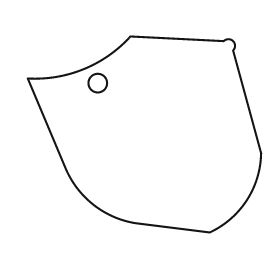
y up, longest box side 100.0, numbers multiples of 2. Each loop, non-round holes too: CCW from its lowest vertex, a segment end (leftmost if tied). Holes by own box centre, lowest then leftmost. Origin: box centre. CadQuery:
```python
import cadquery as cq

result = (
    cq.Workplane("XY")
    .moveTo(28.0, -42.0)
    .threePointArc((44.0, -28.0), (50.0, -8.0))
    .lineTo(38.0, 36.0)
    .threePointArc((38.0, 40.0), (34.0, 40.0))
    .lineTo(-6.0, 42.0)
    .threePointArc((-26.0, 28.0), (-50.0, 24.0))
    .lineTo(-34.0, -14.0)
    .threePointArc((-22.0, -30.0), (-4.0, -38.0))
    .close()
    .moveTo(-20.0, 22.0)
    .circle(4.0)
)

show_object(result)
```